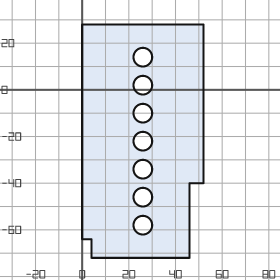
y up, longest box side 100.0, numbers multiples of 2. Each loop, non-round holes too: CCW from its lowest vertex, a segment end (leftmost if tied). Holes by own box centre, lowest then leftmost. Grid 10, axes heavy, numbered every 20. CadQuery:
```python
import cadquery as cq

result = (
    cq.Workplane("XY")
    .moveTo(4.0, -72.0)
    .lineTo(46.0, -72.0)
    .lineTo(46.0, -40.0)
    .lineTo(52.0, -40.0)
    .lineTo(52.0, 28.0)
    .lineTo(0.0, 28.0)
    .lineTo(0.0, -64.0)
    .lineTo(4.0, -64.0)
    .close()
    .moveTo(26.0, -58.0)
    .circle(4.0)
    .moveTo(26.0, -46.0)
    .circle(4.0)
    .moveTo(26.0, -34.0)
    .circle(4.0)
    .moveTo(26.0, -22.0)
    .circle(4.0)
    .moveTo(26.0, -10.0)
    .circle(4.0)
    .moveTo(26.0, 2.0)
    .circle(4.0)
    .moveTo(26.0, 14.0)
    .circle(4.0)
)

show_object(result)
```